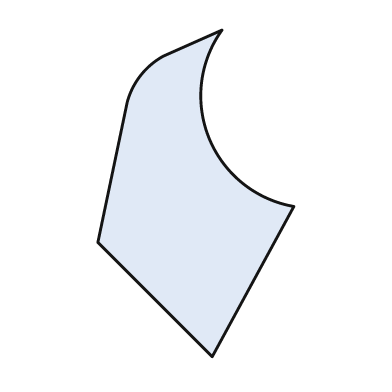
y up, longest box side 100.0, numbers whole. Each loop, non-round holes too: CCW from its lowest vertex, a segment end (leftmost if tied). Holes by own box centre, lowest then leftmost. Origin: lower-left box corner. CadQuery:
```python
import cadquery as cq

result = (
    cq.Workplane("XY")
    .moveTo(35.0, 0.0)
    .lineTo(60.0, 46.0)
    .threePointArc((34.0, 67.0), (38.0, 100.0))
    .lineTo(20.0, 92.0)
    .threePointArc((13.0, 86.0), (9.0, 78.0))
    .lineTo(0.0, 35.0)
    .close()
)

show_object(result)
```